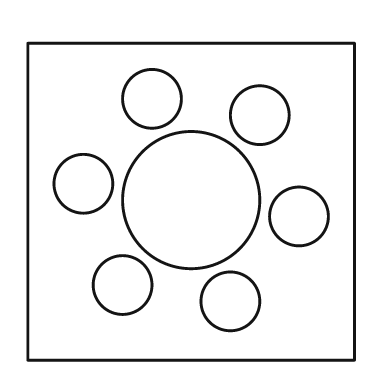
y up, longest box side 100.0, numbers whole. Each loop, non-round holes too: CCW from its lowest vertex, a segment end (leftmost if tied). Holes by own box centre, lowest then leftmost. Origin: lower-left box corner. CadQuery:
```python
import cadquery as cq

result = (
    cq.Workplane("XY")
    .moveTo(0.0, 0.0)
    .lineTo(100.0, 0.0)
    .lineTo(100.0, 97.0)
    .lineTo(0.0, 97.0)
    .close()
    .moveTo(62.0, 18.0)
    .circle(9.0)
    .moveTo(29.0, 23.0)
    .circle(9.0)
    .moveTo(83.0, 44.0)
    .circle(9.0)
    .moveTo(50.0, 49.0)
    .circle(21.0)
    .moveTo(17.0, 54.0)
    .circle(9.0)
    .moveTo(71.0, 75.0)
    .circle(9.0)
    .moveTo(38.0, 80.0)
    .circle(9.0)
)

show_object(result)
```